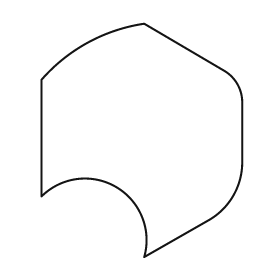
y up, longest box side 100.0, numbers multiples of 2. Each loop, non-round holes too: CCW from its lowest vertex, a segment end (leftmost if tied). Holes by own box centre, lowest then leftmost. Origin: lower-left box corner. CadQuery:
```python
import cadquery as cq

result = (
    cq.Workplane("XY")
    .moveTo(44.0, 0.0)
    .lineTo(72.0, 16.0)
    .threePointArc((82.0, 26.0), (86.0, 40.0))
    .lineTo(86.0, 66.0)
    .threePointArc((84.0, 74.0), (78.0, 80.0))
    .lineTo(44.0, 100.0)
    .threePointArc((20.0, 92.0), (0.0, 76.0))
    .lineTo(0.0, 26.0)
    .threePointArc((32.0, 30.0), (44.0, 0.0))
    .close()
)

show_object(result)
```